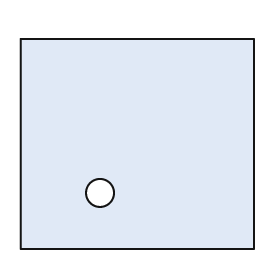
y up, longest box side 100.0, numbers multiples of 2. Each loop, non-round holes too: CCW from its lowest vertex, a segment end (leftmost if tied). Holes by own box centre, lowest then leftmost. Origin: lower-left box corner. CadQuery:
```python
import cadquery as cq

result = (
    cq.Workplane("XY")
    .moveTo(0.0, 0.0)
    .lineTo(100.0, 0.0)
    .lineTo(100.0, 90.0)
    .lineTo(0.0, 90.0)
    .close()
    .moveTo(34.0, 24.0)
    .circle(6.0)
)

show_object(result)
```